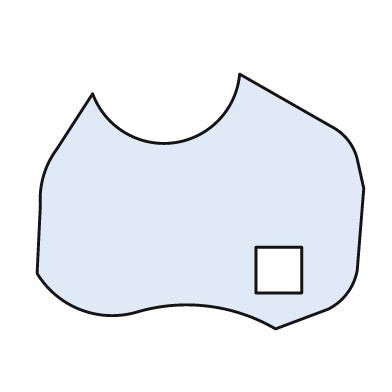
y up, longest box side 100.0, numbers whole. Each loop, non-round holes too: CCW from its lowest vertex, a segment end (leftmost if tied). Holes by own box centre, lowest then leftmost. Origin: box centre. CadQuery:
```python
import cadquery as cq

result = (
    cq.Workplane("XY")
    .moveTo(23.0, -39.0)
    .lineTo(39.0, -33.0)
    .threePointArc((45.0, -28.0), (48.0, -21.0))
    .lineTo(50.0, 4.0)
    .lineTo(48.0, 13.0)
    .threePointArc((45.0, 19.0), (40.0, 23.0))
    .lineTo(12.0, 39.0)
    .threePointArc((-8.0, 18.0), (-33.0, 33.0))
    .lineTo(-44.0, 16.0)
    .threePointArc((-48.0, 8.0), (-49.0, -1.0))
    .lineTo(-50.0, -22.0)
    .threePointArc((-37.0, -33.0), (-20.0, -34.0))
    .threePointArc((2.0, -32.0), (23.0, -39.0))
    .close()
    .moveTo(17.0, -28.0)
    .lineTo(31.0, -28.0)
    .lineTo(31.0, -14.0)
    .lineTo(17.0, -14.0)
    .close()
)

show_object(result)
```